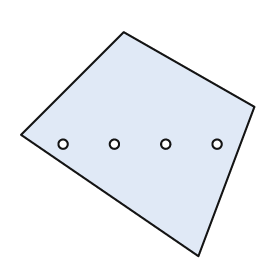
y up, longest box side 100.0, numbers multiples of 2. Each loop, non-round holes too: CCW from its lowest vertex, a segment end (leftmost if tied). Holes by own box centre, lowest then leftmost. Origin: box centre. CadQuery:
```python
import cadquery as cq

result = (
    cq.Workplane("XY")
    .moveTo(26.0, -48.0)
    .lineTo(50.0, 16.0)
    .lineTo(-6.0, 48.0)
    .lineTo(-50.0, 4.0)
    .close()
    .moveTo(-32.0, 0.0)
    .circle(2.0)
    .moveTo(-10.0, 0.0)
    .circle(2.0)
    .moveTo(12.0, 0.0)
    .circle(2.0)
    .moveTo(34.0, 0.0)
    .circle(2.0)
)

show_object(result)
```